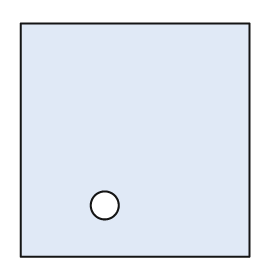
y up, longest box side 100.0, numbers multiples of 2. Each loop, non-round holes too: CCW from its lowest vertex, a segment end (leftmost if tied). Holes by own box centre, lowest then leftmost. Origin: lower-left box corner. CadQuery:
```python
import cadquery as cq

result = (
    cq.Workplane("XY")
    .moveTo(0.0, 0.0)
    .lineTo(98.0, 0.0)
    .lineTo(98.0, 100.0)
    .lineTo(0.0, 100.0)
    .close()
    .moveTo(36.0, 22.0)
    .circle(6.0)
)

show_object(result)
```